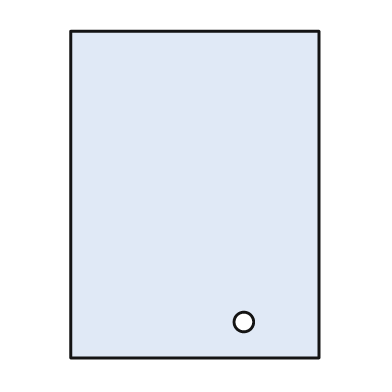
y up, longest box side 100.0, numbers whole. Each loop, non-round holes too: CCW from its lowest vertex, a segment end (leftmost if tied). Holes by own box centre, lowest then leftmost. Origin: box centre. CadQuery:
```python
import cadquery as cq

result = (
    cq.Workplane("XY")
    .moveTo(-38.0, -50.0)
    .lineTo(38.0, -50.0)
    .lineTo(38.0, 50.0)
    .lineTo(-38.0, 50.0)
    .close()
    .moveTo(15.0, -39.0)
    .circle(3.0)
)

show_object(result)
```